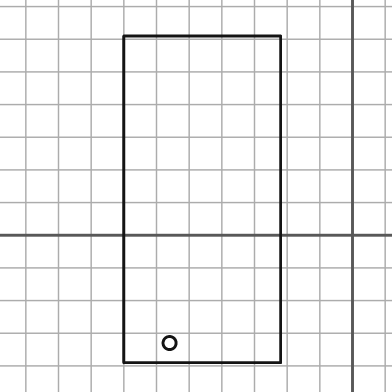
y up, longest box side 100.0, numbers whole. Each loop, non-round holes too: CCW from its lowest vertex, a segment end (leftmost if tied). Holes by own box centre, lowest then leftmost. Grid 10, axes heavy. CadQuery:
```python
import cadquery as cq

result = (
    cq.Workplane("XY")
    .moveTo(-70.0, -39.0)
    .lineTo(-22.0, -39.0)
    .lineTo(-22.0, 61.0)
    .lineTo(-70.0, 61.0)
    .close()
    .moveTo(-56.0, -33.0)
    .circle(2.0)
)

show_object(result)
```